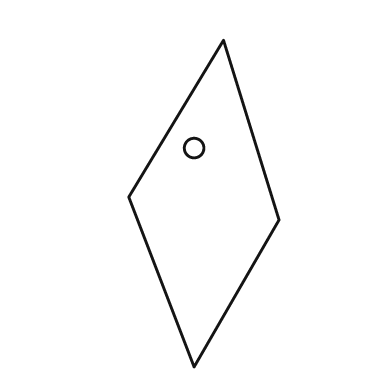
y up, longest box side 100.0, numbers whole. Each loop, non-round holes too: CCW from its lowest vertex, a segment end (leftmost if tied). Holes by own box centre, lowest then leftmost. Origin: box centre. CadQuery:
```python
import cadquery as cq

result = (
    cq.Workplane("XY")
    .moveTo(-3.0, -50.0)
    .lineTo(23.0, -5.0)
    .lineTo(6.0, 50.0)
    .lineTo(-23.0, 2.0)
    .close()
    .moveTo(-3.0, 17.0)
    .circle(3.0)
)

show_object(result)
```